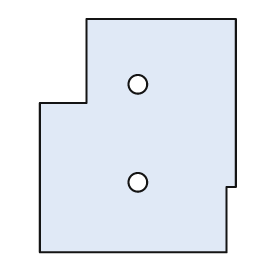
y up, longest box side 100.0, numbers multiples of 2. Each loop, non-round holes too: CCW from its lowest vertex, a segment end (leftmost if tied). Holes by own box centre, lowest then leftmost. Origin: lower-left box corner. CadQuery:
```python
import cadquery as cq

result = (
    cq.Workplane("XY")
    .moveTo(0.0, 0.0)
    .lineTo(80.0, 0.0)
    .lineTo(80.0, 28.0)
    .lineTo(84.0, 28.0)
    .lineTo(84.0, 100.0)
    .lineTo(20.0, 100.0)
    .lineTo(20.0, 64.0)
    .lineTo(0.0, 64.0)
    .close()
    .moveTo(42.0, 30.0)
    .circle(4.0)
    .moveTo(42.0, 72.0)
    .circle(4.0)
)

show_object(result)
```